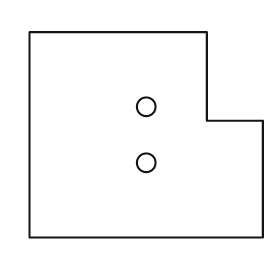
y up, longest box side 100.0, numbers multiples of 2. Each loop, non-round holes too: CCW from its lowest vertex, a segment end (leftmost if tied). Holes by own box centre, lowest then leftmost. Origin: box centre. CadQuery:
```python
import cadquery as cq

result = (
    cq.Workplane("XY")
    .moveTo(-50.0, -44.0)
    .lineTo(50.0, -44.0)
    .lineTo(50.0, 6.0)
    .lineTo(26.0, 6.0)
    .lineTo(26.0, 44.0)
    .lineTo(-50.0, 44.0)
    .close()
    .moveTo(0.0, -12.0)
    .circle(4.0)
    .moveTo(0.0, 12.0)
    .circle(4.0)
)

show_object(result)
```